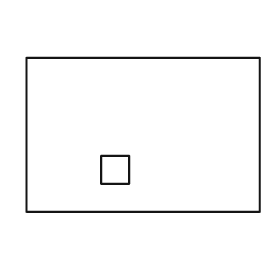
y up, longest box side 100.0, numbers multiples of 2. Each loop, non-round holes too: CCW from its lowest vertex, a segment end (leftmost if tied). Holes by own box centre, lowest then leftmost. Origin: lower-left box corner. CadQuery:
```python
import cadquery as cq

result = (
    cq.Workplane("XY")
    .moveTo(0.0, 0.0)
    .lineTo(100.0, 0.0)
    .lineTo(100.0, 66.0)
    .lineTo(0.0, 66.0)
    .close()
    .moveTo(32.0, 12.0)
    .lineTo(44.0, 12.0)
    .lineTo(44.0, 24.0)
    .lineTo(32.0, 24.0)
    .close()
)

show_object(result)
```